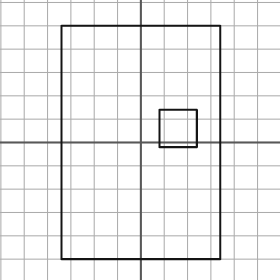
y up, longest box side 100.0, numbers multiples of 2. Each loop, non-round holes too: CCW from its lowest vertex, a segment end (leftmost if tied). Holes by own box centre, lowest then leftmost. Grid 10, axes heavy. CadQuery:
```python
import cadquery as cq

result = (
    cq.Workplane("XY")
    .moveTo(-34.0, -50.0)
    .lineTo(34.0, -50.0)
    .lineTo(34.0, 50.0)
    .lineTo(-34.0, 50.0)
    .close()
    .moveTo(8.0, -2.0)
    .lineTo(24.0, -2.0)
    .lineTo(24.0, 14.0)
    .lineTo(8.0, 14.0)
    .close()
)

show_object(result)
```